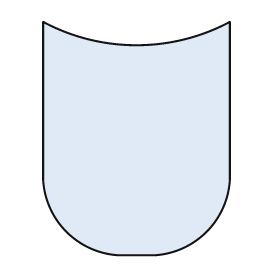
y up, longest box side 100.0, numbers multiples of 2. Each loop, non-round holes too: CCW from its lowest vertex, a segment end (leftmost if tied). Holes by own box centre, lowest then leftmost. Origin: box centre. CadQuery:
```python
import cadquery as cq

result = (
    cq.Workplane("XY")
    .moveTo(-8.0, -50.0)
    .lineTo(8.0, -50.0)
    .threePointArc((30.0, -40.0), (40.0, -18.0))
    .lineTo(40.0, 50.0)
    .threePointArc((0.0, 40.0), (-40.0, 50.0))
    .lineTo(-40.0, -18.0)
    .threePointArc((-30.0, -40.0), (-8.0, -50.0))
    .close()
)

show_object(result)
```